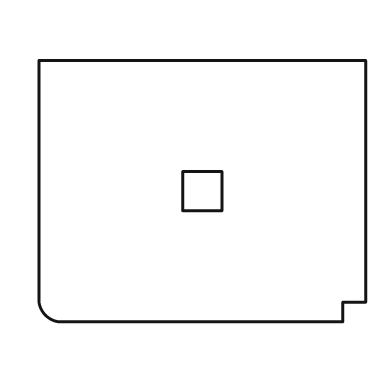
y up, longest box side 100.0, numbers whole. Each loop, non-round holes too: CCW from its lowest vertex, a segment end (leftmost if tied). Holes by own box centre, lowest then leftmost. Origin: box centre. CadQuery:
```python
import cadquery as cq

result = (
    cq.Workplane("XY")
    .moveTo(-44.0, -40.0)
    .lineTo(43.0, -40.0)
    .lineTo(43.0, -34.0)
    .lineTo(50.0, -34.0)
    .lineTo(50.0, 40.0)
    .lineTo(-50.0, 40.0)
    .lineTo(-50.0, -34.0)
    .threePointArc((-48.0, -38.0), (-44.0, -40.0))
    .close()
    .moveTo(-6.0, -6.0)
    .lineTo(6.0, -6.0)
    .lineTo(6.0, 6.0)
    .lineTo(-6.0, 6.0)
    .close()
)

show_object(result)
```